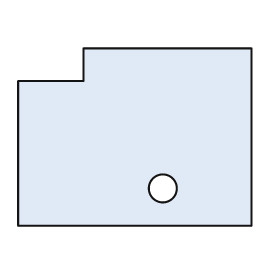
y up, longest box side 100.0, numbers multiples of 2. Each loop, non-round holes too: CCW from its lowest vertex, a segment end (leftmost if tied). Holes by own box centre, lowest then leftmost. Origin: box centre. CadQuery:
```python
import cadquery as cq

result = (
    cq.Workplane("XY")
    .moveTo(-50.0, -38.0)
    .lineTo(50.0, -38.0)
    .lineTo(50.0, 38.0)
    .lineTo(-22.0, 38.0)
    .lineTo(-22.0, 24.0)
    .lineTo(-50.0, 24.0)
    .close()
    .moveTo(12.0, -22.0)
    .circle(6.0)
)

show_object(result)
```